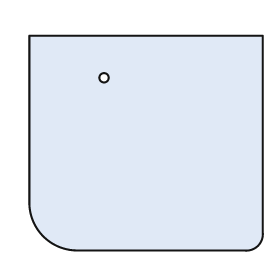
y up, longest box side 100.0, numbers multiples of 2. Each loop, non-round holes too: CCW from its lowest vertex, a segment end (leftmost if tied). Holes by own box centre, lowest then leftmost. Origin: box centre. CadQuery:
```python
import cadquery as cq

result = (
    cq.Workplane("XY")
    .moveTo(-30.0, -46.0)
    .lineTo(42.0, -46.0)
    .threePointArc((48.0, -44.0), (50.0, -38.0))
    .lineTo(50.0, 46.0)
    .lineTo(-50.0, 46.0)
    .lineTo(-50.0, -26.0)
    .threePointArc((-44.0, -40.0), (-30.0, -46.0))
    .close()
    .moveTo(-18.0, 28.0)
    .circle(2.0)
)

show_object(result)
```